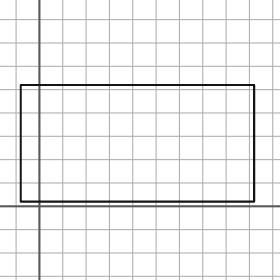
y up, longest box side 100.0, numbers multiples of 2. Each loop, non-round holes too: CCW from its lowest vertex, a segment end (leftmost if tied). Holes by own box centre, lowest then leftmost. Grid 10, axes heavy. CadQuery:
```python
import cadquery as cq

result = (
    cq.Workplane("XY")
    .moveTo(-8.0, 2.0)
    .lineTo(92.0, 2.0)
    .lineTo(92.0, 52.0)
    .lineTo(-8.0, 52.0)
    .close()
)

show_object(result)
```